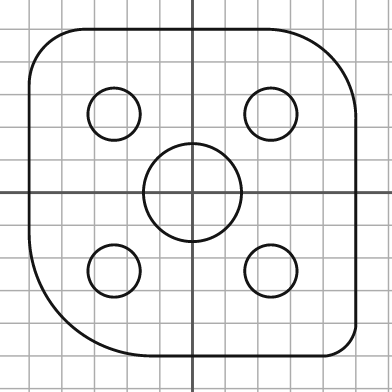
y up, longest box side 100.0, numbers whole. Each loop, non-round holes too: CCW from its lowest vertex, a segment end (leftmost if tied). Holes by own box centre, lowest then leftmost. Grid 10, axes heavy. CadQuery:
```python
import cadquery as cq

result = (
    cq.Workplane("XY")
    .moveTo(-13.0, -50.0)
    .lineTo(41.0, -50.0)
    .threePointArc((47.0, -47.0), (50.0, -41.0))
    .lineTo(50.0, 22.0)
    .threePointArc((42.0, 42.0), (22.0, 50.0))
    .lineTo(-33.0, 50.0)
    .threePointArc((-45.0, 45.0), (-50.0, 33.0))
    .lineTo(-50.0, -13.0)
    .threePointArc((-39.0, -39.0), (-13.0, -50.0))
    .close()
    .moveTo(-24.0, -24.0)
    .circle(8.0)
    .moveTo(24.0, -24.0)
    .circle(8.0)
    .moveTo(0.0, 0.0)
    .circle(15.0)
    .moveTo(-24.0, 24.0)
    .circle(8.0)
    .moveTo(24.0, 24.0)
    .circle(8.0)
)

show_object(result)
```